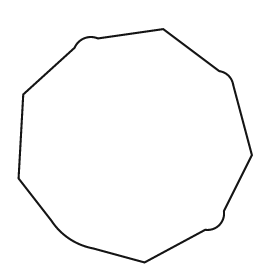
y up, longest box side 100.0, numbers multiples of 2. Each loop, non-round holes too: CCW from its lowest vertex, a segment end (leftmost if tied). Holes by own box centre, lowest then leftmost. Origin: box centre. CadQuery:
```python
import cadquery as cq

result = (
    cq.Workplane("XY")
    .moveTo(4.0, -50.0)
    .lineTo(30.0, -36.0)
    .threePointArc((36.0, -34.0), (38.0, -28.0))
    .lineTo(50.0, -4.0)
    .lineTo(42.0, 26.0)
    .threePointArc((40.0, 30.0), (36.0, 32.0))
    .lineTo(12.0, 50.0)
    .lineTo(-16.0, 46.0)
    .threePointArc((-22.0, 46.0), (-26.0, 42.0))
    .lineTo(-48.0, 22.0)
    .lineTo(-50.0, -14.0)
    .lineTo(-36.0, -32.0)
    .threePointArc((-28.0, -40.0), (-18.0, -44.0))
    .close()
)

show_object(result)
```